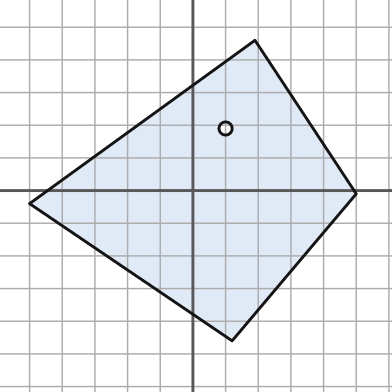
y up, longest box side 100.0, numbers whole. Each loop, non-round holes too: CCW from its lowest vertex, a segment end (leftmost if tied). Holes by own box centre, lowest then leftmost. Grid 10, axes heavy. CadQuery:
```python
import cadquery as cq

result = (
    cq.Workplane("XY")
    .moveTo(12.0, -46.0)
    .lineTo(50.0, -1.0)
    .lineTo(19.0, 46.0)
    .lineTo(-50.0, -4.0)
    .close()
    .moveTo(10.0, 19.0)
    .circle(2.0)
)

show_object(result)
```